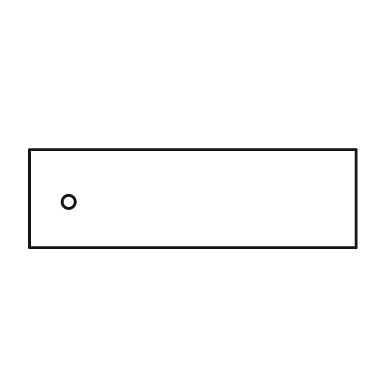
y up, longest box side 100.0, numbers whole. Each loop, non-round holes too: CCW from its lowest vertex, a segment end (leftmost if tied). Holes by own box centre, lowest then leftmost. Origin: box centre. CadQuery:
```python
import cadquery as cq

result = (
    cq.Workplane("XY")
    .moveTo(-50.0, -15.0)
    .lineTo(50.0, -15.0)
    .lineTo(50.0, 15.0)
    .lineTo(-50.0, 15.0)
    .close()
    .moveTo(-38.0, -1.0)
    .circle(2.0)
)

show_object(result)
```